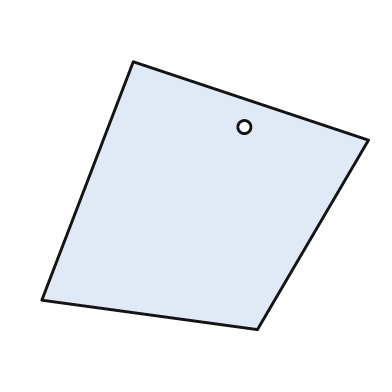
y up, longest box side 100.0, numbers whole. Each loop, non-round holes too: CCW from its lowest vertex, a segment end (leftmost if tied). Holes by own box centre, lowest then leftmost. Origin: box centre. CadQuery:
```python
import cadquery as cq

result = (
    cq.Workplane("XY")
    .moveTo(16.0, -41.0)
    .lineTo(50.0, 17.0)
    .lineTo(-22.0, 41.0)
    .lineTo(-50.0, -32.0)
    .close()
    .moveTo(12.0, 21.0)
    .circle(2.0)
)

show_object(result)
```